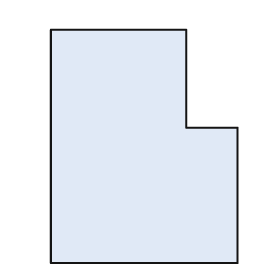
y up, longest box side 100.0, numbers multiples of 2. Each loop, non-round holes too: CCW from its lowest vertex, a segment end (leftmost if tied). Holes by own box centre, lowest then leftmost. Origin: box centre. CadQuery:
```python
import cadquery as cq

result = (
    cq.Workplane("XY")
    .moveTo(-40.0, -50.0)
    .lineTo(40.0, -50.0)
    .lineTo(40.0, 8.0)
    .lineTo(18.0, 8.0)
    .lineTo(18.0, 50.0)
    .lineTo(-40.0, 50.0)
    .close()
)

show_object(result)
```